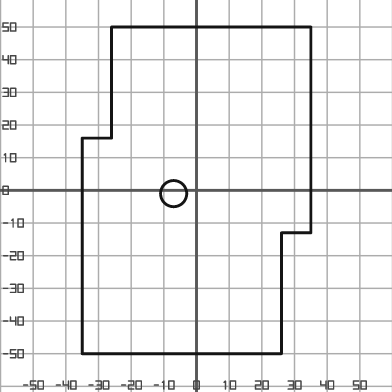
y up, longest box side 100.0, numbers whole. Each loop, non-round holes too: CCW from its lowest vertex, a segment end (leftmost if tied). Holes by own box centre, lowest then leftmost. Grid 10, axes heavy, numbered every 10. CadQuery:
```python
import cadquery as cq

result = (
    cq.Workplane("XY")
    .moveTo(-35.0, -50.0)
    .lineTo(26.0, -50.0)
    .lineTo(26.0, -13.0)
    .lineTo(35.0, -13.0)
    .lineTo(35.0, 50.0)
    .lineTo(-26.0, 50.0)
    .lineTo(-26.0, 16.0)
    .lineTo(-35.0, 16.0)
    .close()
    .moveTo(-7.0, -1.0)
    .circle(4.0)
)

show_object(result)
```